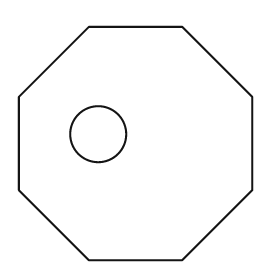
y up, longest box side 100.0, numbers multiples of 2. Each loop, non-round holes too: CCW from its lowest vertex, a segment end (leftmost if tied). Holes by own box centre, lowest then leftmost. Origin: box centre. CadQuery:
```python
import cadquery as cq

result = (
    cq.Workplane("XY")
    .moveTo(-20.0, -50.0)
    .lineTo(20.0, -50.0)
    .lineTo(50.0, -20.0)
    .lineTo(50.0, 20.0)
    .lineTo(20.0, 50.0)
    .lineTo(-20.0, 50.0)
    .lineTo(-50.0, 20.0)
    .lineTo(-50.0, -20.0)
    .close()
    .moveTo(-16.0, 4.0)
    .circle(12.0)
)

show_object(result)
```